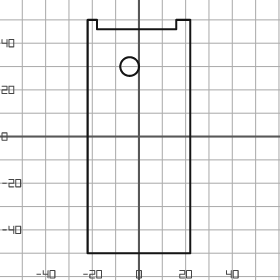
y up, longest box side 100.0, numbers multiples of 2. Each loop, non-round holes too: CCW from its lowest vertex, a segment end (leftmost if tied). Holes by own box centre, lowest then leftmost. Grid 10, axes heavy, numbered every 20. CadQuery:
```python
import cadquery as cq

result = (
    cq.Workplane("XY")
    .moveTo(-22.0, -50.0)
    .lineTo(22.0, -50.0)
    .lineTo(22.0, 50.0)
    .lineTo(16.0, 50.0)
    .lineTo(16.0, 46.0)
    .lineTo(-18.0, 46.0)
    .lineTo(-18.0, 50.0)
    .lineTo(-22.0, 50.0)
    .close()
    .moveTo(-4.0, 30.0)
    .circle(4.0)
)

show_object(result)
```